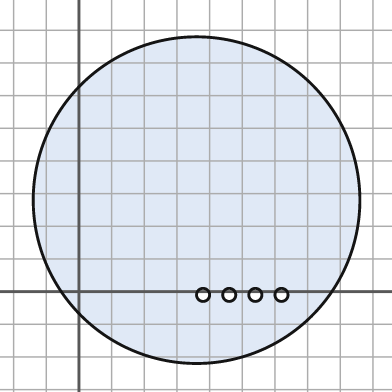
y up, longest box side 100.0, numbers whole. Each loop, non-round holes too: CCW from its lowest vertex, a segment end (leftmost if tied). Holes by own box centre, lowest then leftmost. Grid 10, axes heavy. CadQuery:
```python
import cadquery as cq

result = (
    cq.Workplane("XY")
    .moveTo(36.0, 28.0)
    .circle(50.0)
    .moveTo(38.0, -1.0)
    .circle(2.0)
    .moveTo(46.0, -1.0)
    .circle(2.0)
    .moveTo(54.0, -1.0)
    .circle(2.0)
    .moveTo(62.0, -1.0)
    .circle(2.0)
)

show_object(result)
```